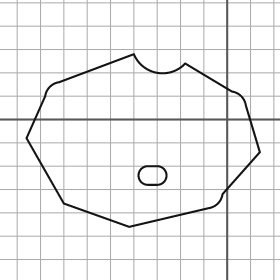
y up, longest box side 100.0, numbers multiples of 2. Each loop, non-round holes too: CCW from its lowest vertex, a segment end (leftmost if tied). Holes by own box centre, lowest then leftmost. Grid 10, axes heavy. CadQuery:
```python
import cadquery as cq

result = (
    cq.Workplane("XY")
    .moveTo(-42.0, -46.0)
    .lineTo(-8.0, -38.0)
    .threePointArc((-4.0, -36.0), (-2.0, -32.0))
    .lineTo(14.0, -14.0)
    .lineTo(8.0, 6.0)
    .threePointArc((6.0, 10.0), (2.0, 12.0))
    .lineTo(-18.0, 24.0)
    .threePointArc((-30.0, 20.0), (-40.0, 28.0))
    .lineTo(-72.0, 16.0)
    .threePointArc((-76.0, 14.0), (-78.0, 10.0))
    .lineTo(-86.0, -8.0)
    .lineTo(-70.0, -36.0)
    .close()
    .moveTo(-34.0, -28.0)
    .lineTo(-30.0, -28.0)
    .threePointArc((-26.0, -24.0), (-30.0, -20.0))
    .lineTo(-34.0, -20.0)
    .threePointArc((-38.0, -24.0), (-34.0, -28.0))
    .close()
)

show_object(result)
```